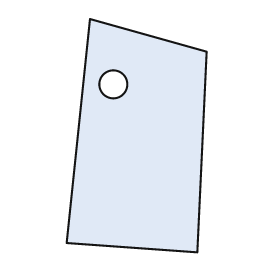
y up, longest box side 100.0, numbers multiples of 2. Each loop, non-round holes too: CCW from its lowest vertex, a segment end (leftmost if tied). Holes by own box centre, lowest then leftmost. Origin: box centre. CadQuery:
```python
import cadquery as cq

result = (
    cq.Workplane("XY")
    .moveTo(26.0, -50.0)
    .lineTo(30.0, 36.0)
    .lineTo(-20.0, 50.0)
    .lineTo(-30.0, -46.0)
    .close()
    .moveTo(-10.0, 22.0)
    .circle(6.0)
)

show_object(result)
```